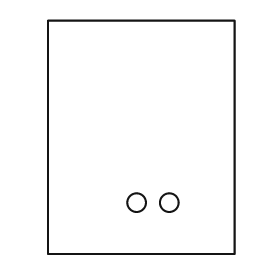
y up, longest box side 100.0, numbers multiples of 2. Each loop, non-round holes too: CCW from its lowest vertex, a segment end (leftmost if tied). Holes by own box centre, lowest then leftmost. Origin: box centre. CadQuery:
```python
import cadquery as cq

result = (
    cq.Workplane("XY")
    .moveTo(-40.0, -50.0)
    .lineTo(40.0, -50.0)
    .lineTo(40.0, 50.0)
    .lineTo(-40.0, 50.0)
    .close()
    .moveTo(-2.0, -28.0)
    .circle(4.0)
    .moveTo(12.0, -28.0)
    .circle(4.0)
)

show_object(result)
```